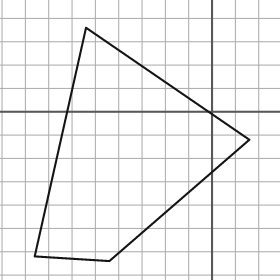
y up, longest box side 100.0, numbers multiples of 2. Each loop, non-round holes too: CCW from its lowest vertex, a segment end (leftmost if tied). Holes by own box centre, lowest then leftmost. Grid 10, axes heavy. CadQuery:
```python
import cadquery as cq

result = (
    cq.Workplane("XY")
    .moveTo(-44.0, -64.0)
    .lineTo(16.0, -12.0)
    .lineTo(-54.0, 36.0)
    .lineTo(-76.0, -62.0)
    .close()
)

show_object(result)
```